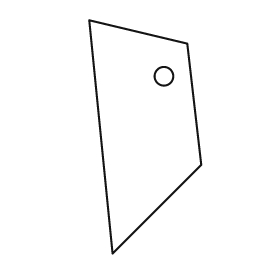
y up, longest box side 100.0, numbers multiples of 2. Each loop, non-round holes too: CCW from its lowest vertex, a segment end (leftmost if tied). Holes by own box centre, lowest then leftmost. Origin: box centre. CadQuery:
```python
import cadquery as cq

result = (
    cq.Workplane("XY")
    .moveTo(-14.0, -50.0)
    .lineTo(24.0, -12.0)
    .lineTo(18.0, 40.0)
    .lineTo(-24.0, 50.0)
    .close()
    .moveTo(8.0, 26.0)
    .circle(4.0)
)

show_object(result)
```